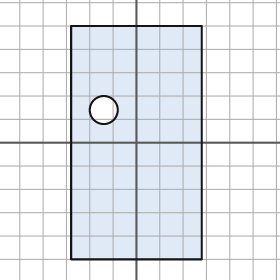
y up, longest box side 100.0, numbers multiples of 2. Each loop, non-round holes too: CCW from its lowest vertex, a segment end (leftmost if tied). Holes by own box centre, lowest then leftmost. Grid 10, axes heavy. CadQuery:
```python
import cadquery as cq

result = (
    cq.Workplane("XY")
    .moveTo(-28.0, -50.0)
    .lineTo(28.0, -50.0)
    .lineTo(28.0, 50.0)
    .lineTo(-28.0, 50.0)
    .close()
    .moveTo(-14.0, 14.0)
    .circle(6.0)
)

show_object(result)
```